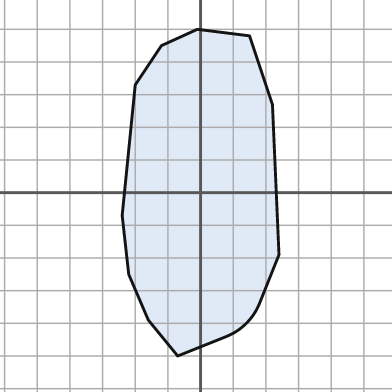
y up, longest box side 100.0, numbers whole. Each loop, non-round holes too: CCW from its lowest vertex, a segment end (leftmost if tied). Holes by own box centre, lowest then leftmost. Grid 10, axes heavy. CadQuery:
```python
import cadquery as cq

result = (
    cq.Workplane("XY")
    .moveTo(-7.0, -50.0)
    .lineTo(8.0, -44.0)
    .threePointArc((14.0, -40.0), (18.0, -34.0))
    .lineTo(24.0, -19.0)
    .lineTo(22.0, 27.0)
    .lineTo(15.0, 48.0)
    .lineTo(-1.0, 50.0)
    .lineTo(-12.0, 45.0)
    .lineTo(-20.0, 33.0)
    .lineTo(-24.0, -7.0)
    .lineTo(-22.0, -25.0)
    .lineTo(-16.0, -39.0)
    .close()
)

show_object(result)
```